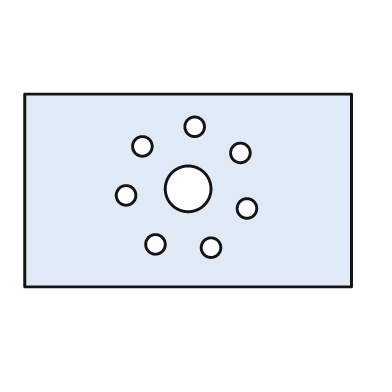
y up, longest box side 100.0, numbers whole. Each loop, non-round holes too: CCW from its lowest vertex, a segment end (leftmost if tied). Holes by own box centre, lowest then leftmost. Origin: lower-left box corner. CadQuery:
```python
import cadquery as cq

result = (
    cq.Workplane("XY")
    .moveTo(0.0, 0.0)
    .lineTo(100.0, 0.0)
    .lineTo(100.0, 59.0)
    .lineTo(0.0, 59.0)
    .close()
    .moveTo(57.0, 12.0)
    .circle(3.0)
    .moveTo(40.0, 13.0)
    .circle(3.0)
    .moveTo(68.0, 24.0)
    .circle(3.0)
    .moveTo(31.0, 28.0)
    .circle(3.0)
    .moveTo(50.0, 30.0)
    .circle(7.0)
    .moveTo(66.0, 41.0)
    .circle(3.0)
    .moveTo(36.0, 43.0)
    .circle(3.0)
    .moveTo(52.0, 49.0)
    .circle(3.0)
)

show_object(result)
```